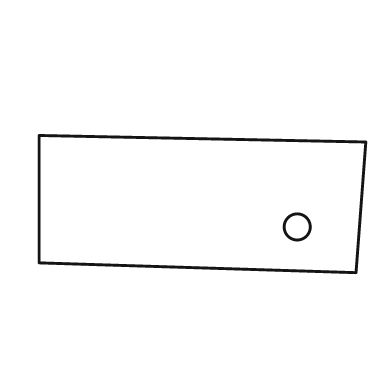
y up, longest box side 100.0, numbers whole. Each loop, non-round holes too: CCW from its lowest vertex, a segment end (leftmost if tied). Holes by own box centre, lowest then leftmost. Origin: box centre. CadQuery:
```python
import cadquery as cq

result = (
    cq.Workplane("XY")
    .moveTo(47.0, -21.0)
    .lineTo(50.0, 19.0)
    .lineTo(-50.0, 21.0)
    .lineTo(-50.0, -18.0)
    .close()
    .moveTo(29.0, -7.0)
    .circle(4.0)
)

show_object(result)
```